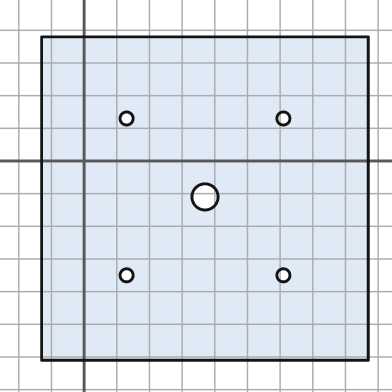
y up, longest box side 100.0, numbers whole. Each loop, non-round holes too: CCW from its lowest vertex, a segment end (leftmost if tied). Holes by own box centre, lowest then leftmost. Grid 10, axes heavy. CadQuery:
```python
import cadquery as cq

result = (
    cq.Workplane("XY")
    .moveTo(-13.0, -61.0)
    .lineTo(87.0, -61.0)
    .lineTo(87.0, 38.0)
    .lineTo(-13.0, 38.0)
    .close()
    .moveTo(13.0, -35.0)
    .circle(2.0)
    .moveTo(61.0, -35.0)
    .circle(2.0)
    .moveTo(37.0, -11.0)
    .circle(4.0)
    .moveTo(13.0, 13.0)
    .circle(2.0)
    .moveTo(61.0, 13.0)
    .circle(2.0)
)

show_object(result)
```